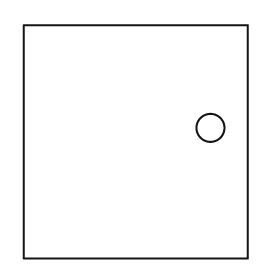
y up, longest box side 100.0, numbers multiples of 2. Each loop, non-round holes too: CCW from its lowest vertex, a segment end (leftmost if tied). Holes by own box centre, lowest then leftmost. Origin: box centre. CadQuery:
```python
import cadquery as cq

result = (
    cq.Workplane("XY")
    .moveTo(-48.0, -50.0)
    .lineTo(48.0, -50.0)
    .lineTo(48.0, 50.0)
    .lineTo(-48.0, 50.0)
    .close()
    .moveTo(32.0, 6.0)
    .circle(6.0)
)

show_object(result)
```